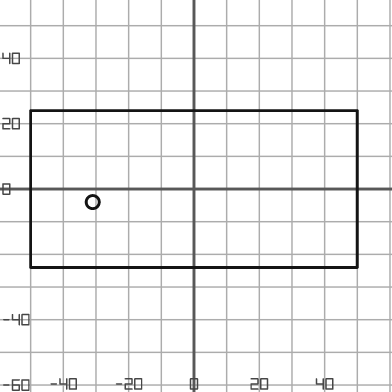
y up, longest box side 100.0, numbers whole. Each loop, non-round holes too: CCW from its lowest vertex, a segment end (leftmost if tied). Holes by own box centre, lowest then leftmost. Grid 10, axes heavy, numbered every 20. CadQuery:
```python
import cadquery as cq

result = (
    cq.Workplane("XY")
    .moveTo(-50.0, -24.0)
    .lineTo(50.0, -24.0)
    .lineTo(50.0, 24.0)
    .lineTo(-50.0, 24.0)
    .close()
    .moveTo(-31.0, -4.0)
    .circle(2.0)
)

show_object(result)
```